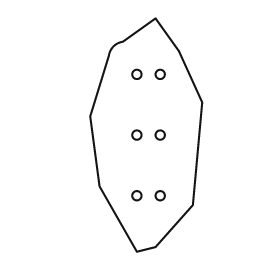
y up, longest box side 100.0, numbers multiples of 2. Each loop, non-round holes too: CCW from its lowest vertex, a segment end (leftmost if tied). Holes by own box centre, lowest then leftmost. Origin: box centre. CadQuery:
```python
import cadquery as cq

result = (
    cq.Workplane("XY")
    .moveTo(-4.0, -50.0)
    .lineTo(4.0, -48.0)
    .lineTo(20.0, -30.0)
    .lineTo(24.0, 14.0)
    .lineTo(14.0, 36.0)
    .lineTo(4.0, 50.0)
    .lineTo(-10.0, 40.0)
    .threePointArc((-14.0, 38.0), (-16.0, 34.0))
    .lineTo(-24.0, 8.0)
    .lineTo(-20.0, -22.0)
    .close()
    .moveTo(-4.0, -26.0)
    .circle(2.0)
    .moveTo(6.0, -26.0)
    .circle(2.0)
    .moveTo(-4.0, 0.0)
    .circle(2.0)
    .moveTo(6.0, 0.0)
    .circle(2.0)
    .moveTo(-4.0, 26.0)
    .circle(2.0)
    .moveTo(6.0, 26.0)
    .circle(2.0)
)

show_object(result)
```